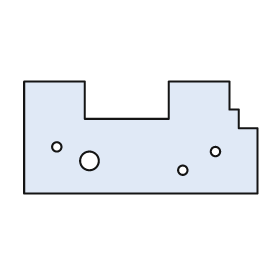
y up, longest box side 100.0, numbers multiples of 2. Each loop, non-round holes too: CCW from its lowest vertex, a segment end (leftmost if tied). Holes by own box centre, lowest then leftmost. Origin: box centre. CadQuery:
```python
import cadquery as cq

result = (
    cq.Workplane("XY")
    .moveTo(-50.0, -24.0)
    .lineTo(50.0, -24.0)
    .lineTo(50.0, 4.0)
    .lineTo(42.0, 4.0)
    .lineTo(42.0, 12.0)
    .lineTo(38.0, 12.0)
    .lineTo(38.0, 24.0)
    .lineTo(12.0, 24.0)
    .lineTo(12.0, 8.0)
    .lineTo(-24.0, 8.0)
    .lineTo(-24.0, 24.0)
    .lineTo(-50.0, 24.0)
    .close()
    .moveTo(18.0, -14.0)
    .circle(2.0)
    .moveTo(-22.0, -10.0)
    .circle(4.0)
    .moveTo(32.0, -6.0)
    .circle(2.0)
    .moveTo(-36.0, -4.0)
    .circle(2.0)
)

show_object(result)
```